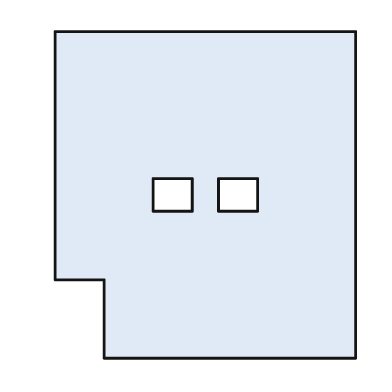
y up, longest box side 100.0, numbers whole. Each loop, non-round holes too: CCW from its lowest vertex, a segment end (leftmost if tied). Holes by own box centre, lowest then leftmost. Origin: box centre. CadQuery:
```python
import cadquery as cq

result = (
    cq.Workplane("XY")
    .moveTo(-31.0, -50.0)
    .lineTo(46.0, -50.0)
    .lineTo(46.0, 50.0)
    .lineTo(-46.0, 50.0)
    .lineTo(-46.0, -26.0)
    .lineTo(-31.0, -26.0)
    .close()
    .moveTo(-16.0, -5.0)
    .lineTo(-4.0, -5.0)
    .lineTo(-4.0, 5.0)
    .lineTo(-16.0, 5.0)
    .close()
    .moveTo(4.0, -5.0)
    .lineTo(16.0, -5.0)
    .lineTo(16.0, 5.0)
    .lineTo(4.0, 5.0)
    .close()
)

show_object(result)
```